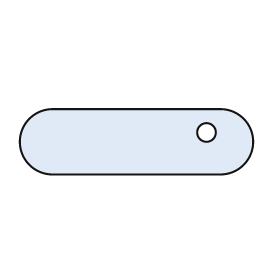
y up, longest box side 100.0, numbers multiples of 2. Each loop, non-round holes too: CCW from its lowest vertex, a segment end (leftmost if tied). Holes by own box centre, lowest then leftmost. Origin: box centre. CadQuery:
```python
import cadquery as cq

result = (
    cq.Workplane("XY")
    .moveTo(-36.0, -14.0)
    .lineTo(36.0, -14.0)
    .threePointArc((50.0, 0.0), (36.0, 14.0))
    .lineTo(-36.0, 14.0)
    .threePointArc((-50.0, 0.0), (-36.0, -14.0))
    .close()
    .moveTo(30.0, 4.0)
    .circle(4.0)
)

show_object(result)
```